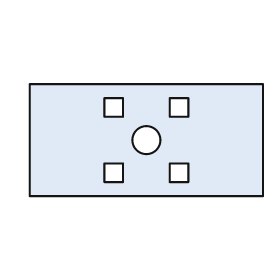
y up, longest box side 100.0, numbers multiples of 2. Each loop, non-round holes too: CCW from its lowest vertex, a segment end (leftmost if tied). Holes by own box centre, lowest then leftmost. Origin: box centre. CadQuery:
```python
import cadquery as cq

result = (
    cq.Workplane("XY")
    .moveTo(-50.0, -24.0)
    .lineTo(50.0, -24.0)
    .lineTo(50.0, 24.0)
    .lineTo(-50.0, 24.0)
    .close()
    .moveTo(-18.0, -18.0)
    .lineTo(-10.0, -18.0)
    .lineTo(-10.0, -10.0)
    .lineTo(-18.0, -10.0)
    .close()
    .moveTo(10.0, -18.0)
    .lineTo(18.0, -18.0)
    .lineTo(18.0, -10.0)
    .lineTo(10.0, -10.0)
    .close()
    .moveTo(0.0, 0.0)
    .circle(6.0)
    .moveTo(-18.0, 10.0)
    .lineTo(-10.0, 10.0)
    .lineTo(-10.0, 18.0)
    .lineTo(-18.0, 18.0)
    .close()
    .moveTo(10.0, 10.0)
    .lineTo(18.0, 10.0)
    .lineTo(18.0, 18.0)
    .lineTo(10.0, 18.0)
    .close()
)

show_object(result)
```